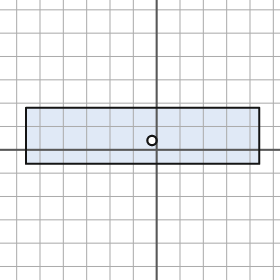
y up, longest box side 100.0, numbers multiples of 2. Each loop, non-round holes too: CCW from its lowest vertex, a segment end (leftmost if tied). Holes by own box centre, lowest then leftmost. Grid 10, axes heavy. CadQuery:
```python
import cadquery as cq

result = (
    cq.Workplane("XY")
    .moveTo(-56.0, -6.0)
    .lineTo(44.0, -6.0)
    .lineTo(44.0, 18.0)
    .lineTo(-56.0, 18.0)
    .close()
    .moveTo(-2.0, 4.0)
    .circle(2.0)
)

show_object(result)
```